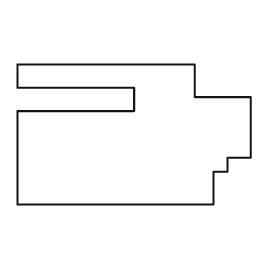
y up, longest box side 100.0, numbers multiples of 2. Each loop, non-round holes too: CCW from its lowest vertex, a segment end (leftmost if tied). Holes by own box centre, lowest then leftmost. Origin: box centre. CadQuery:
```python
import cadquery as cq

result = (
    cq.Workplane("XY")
    .moveTo(-50.0, -30.0)
    .lineTo(34.0, -30.0)
    .lineTo(34.0, -16.0)
    .lineTo(40.0, -16.0)
    .lineTo(40.0, -10.0)
    .lineTo(50.0, -10.0)
    .lineTo(50.0, 16.0)
    .lineTo(26.0, 16.0)
    .lineTo(26.0, 30.0)
    .lineTo(-50.0, 30.0)
    .lineTo(-50.0, 20.0)
    .lineTo(0.0, 20.0)
    .lineTo(0.0, 10.0)
    .lineTo(-50.0, 10.0)
    .close()
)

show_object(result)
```